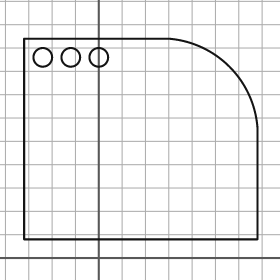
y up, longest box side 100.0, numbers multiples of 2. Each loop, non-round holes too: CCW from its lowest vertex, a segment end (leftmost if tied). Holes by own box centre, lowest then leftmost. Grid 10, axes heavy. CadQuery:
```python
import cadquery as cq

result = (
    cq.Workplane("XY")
    .moveTo(-32.0, 8.0)
    .lineTo(68.0, 8.0)
    .lineTo(68.0, 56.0)
    .threePointArc((56.0, 82.0), (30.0, 94.0))
    .lineTo(-32.0, 94.0)
    .close()
    .moveTo(-24.0, 86.0)
    .circle(4.0)
    .moveTo(-12.0, 86.0)
    .circle(4.0)
    .moveTo(0.0, 86.0)
    .circle(4.0)
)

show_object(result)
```